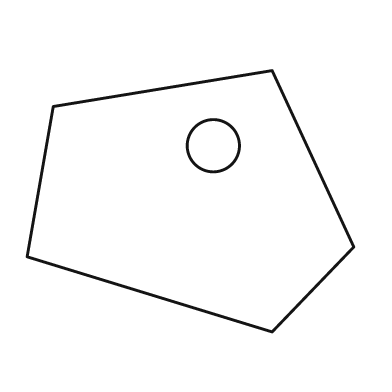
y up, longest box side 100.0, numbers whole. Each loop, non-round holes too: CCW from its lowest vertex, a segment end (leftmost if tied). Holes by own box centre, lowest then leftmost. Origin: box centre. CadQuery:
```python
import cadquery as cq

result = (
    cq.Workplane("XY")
    .moveTo(25.0, -40.0)
    .lineTo(50.0, -14.0)
    .lineTo(25.0, 40.0)
    .lineTo(-42.0, 29.0)
    .lineTo(-50.0, -17.0)
    .close()
    .moveTo(7.0, 17.0)
    .circle(8.0)
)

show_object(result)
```